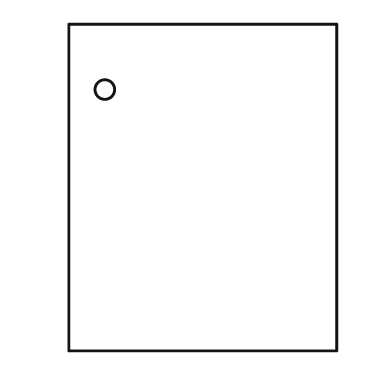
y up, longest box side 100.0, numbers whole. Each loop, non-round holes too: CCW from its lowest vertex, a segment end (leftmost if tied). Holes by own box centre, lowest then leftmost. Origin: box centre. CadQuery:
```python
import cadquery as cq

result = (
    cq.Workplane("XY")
    .moveTo(-41.0, -50.0)
    .lineTo(41.0, -50.0)
    .lineTo(41.0, 50.0)
    .lineTo(-41.0, 50.0)
    .close()
    .moveTo(-30.0, 30.0)
    .circle(3.0)
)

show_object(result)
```